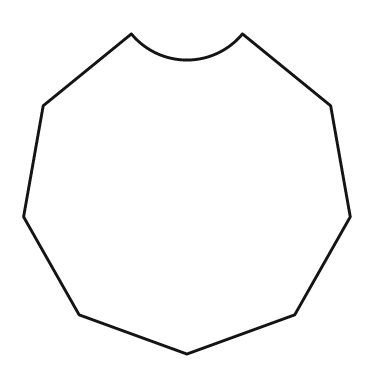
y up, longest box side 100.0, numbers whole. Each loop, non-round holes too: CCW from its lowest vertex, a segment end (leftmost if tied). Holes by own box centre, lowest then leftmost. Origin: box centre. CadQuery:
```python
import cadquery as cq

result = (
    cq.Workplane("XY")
    .moveTo(0.0, -49.0)
    .lineTo(33.0, -37.0)
    .lineTo(50.0, -7.0)
    .lineTo(44.0, 27.0)
    .lineTo(17.0, 49.0)
    .threePointArc((0.0, 41.0), (-17.0, 49.0))
    .lineTo(-44.0, 27.0)
    .lineTo(-50.0, -7.0)
    .lineTo(-33.0, -37.0)
    .close()
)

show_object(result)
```